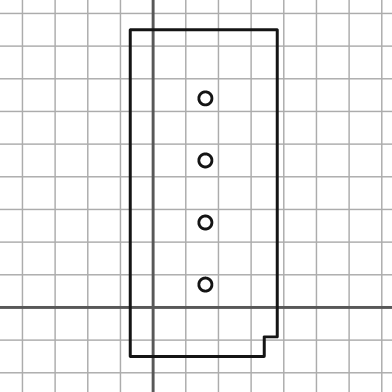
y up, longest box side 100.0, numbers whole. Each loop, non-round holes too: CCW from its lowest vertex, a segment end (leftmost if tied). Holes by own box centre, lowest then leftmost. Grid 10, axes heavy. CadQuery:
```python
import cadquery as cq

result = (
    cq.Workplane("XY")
    .moveTo(-7.0, -15.0)
    .lineTo(34.0, -15.0)
    .lineTo(34.0, -9.0)
    .lineTo(38.0, -9.0)
    .lineTo(38.0, 85.0)
    .lineTo(-7.0, 85.0)
    .close()
    .moveTo(16.0, 7.0)
    .circle(2.0)
    .moveTo(16.0, 26.0)
    .circle(2.0)
    .moveTo(16.0, 45.0)
    .circle(2.0)
    .moveTo(16.0, 64.0)
    .circle(2.0)
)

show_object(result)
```